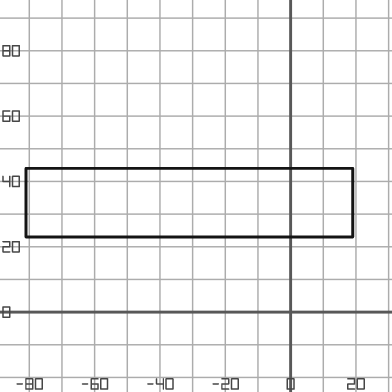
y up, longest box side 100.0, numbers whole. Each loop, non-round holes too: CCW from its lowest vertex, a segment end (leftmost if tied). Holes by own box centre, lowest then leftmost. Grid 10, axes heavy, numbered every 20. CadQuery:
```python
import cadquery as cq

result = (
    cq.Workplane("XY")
    .moveTo(-81.0, 23.0)
    .lineTo(19.0, 23.0)
    .lineTo(19.0, 44.0)
    .lineTo(-81.0, 44.0)
    .close()
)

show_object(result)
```